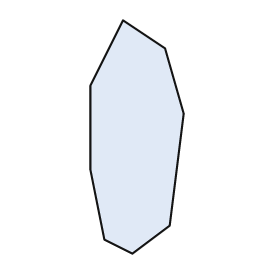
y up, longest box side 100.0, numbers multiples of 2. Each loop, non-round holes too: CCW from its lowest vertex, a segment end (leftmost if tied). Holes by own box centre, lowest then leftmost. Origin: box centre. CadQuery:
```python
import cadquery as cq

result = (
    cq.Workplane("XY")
    .moveTo(-2.0, -50.0)
    .lineTo(14.0, -38.0)
    .lineTo(20.0, 10.0)
    .lineTo(12.0, 38.0)
    .lineTo(-6.0, 50.0)
    .lineTo(-20.0, 22.0)
    .lineTo(-20.0, -14.0)
    .lineTo(-14.0, -44.0)
    .close()
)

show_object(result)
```